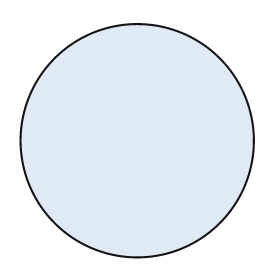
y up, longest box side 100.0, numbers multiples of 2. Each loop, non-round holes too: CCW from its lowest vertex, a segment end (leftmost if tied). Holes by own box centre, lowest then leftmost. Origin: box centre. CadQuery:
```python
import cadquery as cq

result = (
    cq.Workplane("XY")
    .moveTo(0.0, 0.0)
    .circle(50.0)
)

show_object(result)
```